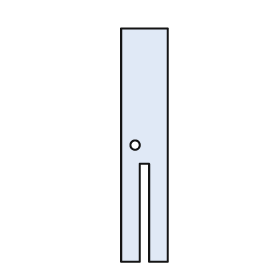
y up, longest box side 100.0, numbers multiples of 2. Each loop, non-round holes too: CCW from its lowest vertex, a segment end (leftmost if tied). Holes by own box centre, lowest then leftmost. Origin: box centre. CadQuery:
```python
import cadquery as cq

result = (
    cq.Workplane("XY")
    .moveTo(-10.0, -50.0)
    .lineTo(-2.0, -50.0)
    .lineTo(-2.0, -8.0)
    .lineTo(2.0, -8.0)
    .lineTo(2.0, -50.0)
    .lineTo(10.0, -50.0)
    .lineTo(10.0, 50.0)
    .lineTo(-10.0, 50.0)
    .close()
    .moveTo(-4.0, 0.0)
    .circle(2.0)
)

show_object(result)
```